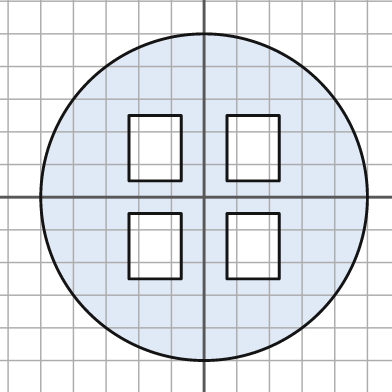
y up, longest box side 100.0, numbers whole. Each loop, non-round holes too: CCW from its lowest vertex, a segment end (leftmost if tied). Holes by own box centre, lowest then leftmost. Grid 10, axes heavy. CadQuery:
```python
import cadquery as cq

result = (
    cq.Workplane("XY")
    .moveTo(0.0, 0.0)
    .circle(50.0)
    .moveTo(-23.0, -25.0)
    .lineTo(-7.0, -25.0)
    .lineTo(-7.0, -5.0)
    .lineTo(-23.0, -5.0)
    .close()
    .moveTo(7.0, -25.0)
    .lineTo(23.0, -25.0)
    .lineTo(23.0, -5.0)
    .lineTo(7.0, -5.0)
    .close()
    .moveTo(-23.0, 5.0)
    .lineTo(-7.0, 5.0)
    .lineTo(-7.0, 25.0)
    .lineTo(-23.0, 25.0)
    .close()
    .moveTo(7.0, 5.0)
    .lineTo(23.0, 5.0)
    .lineTo(23.0, 25.0)
    .lineTo(7.0, 25.0)
    .close()
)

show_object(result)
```